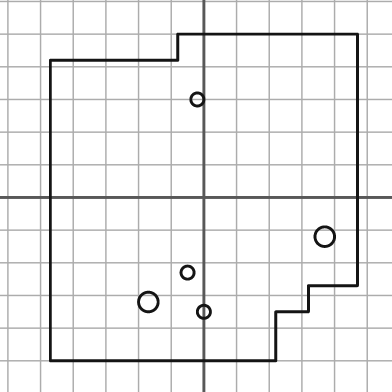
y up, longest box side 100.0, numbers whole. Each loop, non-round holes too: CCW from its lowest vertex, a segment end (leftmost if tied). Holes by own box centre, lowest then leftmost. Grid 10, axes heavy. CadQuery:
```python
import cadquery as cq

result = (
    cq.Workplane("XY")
    .moveTo(-47.0, -50.0)
    .lineTo(22.0, -50.0)
    .lineTo(22.0, -35.0)
    .lineTo(32.0, -35.0)
    .lineTo(32.0, -27.0)
    .lineTo(47.0, -27.0)
    .lineTo(47.0, 50.0)
    .lineTo(-8.0, 50.0)
    .lineTo(-8.0, 42.0)
    .lineTo(-47.0, 42.0)
    .close()
    .moveTo(0.0, -35.0)
    .circle(2.0)
    .moveTo(-17.0, -32.0)
    .circle(3.0)
    .moveTo(-5.0, -23.0)
    .circle(2.0)
    .moveTo(37.0, -12.0)
    .circle(3.0)
    .moveTo(-2.0, 30.0)
    .circle(2.0)
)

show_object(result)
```